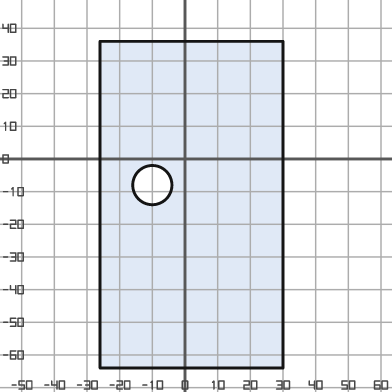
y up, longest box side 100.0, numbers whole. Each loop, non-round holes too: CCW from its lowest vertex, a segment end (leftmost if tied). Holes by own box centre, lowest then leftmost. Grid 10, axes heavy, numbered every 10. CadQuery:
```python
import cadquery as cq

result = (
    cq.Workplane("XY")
    .moveTo(-26.0, -64.0)
    .lineTo(30.0, -64.0)
    .lineTo(30.0, 36.0)
    .lineTo(-26.0, 36.0)
    .close()
    .moveTo(-10.0, -8.0)
    .circle(6.0)
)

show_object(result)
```